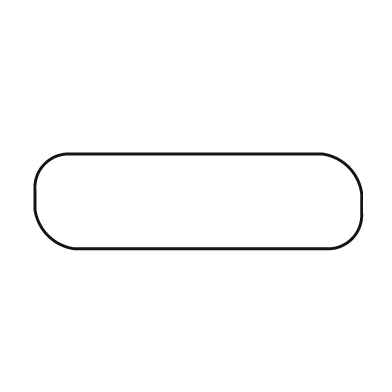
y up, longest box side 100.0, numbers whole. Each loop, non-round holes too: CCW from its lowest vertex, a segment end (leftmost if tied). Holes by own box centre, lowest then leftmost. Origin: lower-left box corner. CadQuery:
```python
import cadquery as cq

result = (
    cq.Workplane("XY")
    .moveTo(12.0, 0.0)
    .lineTo(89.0, 0.0)
    .threePointArc((97.0, 3.0), (100.0, 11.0))
    .lineTo(100.0, 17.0)
    .threePointArc((96.0, 25.0), (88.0, 29.0))
    .lineTo(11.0, 29.0)
    .threePointArc((3.0, 26.0), (0.0, 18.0))
    .lineTo(0.0, 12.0)
    .threePointArc((4.0, 4.0), (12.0, 0.0))
    .close()
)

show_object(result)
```